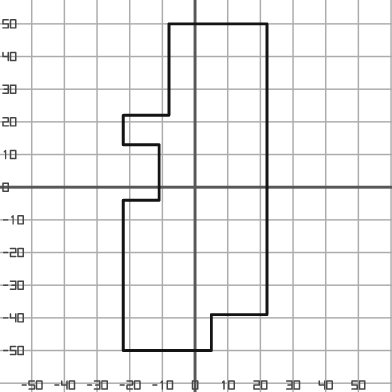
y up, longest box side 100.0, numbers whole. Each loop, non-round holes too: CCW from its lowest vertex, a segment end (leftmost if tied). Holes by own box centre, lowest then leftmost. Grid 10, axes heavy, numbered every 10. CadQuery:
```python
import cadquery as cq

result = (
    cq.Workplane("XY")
    .moveTo(-22.0, -50.0)
    .lineTo(5.0, -50.0)
    .lineTo(5.0, -39.0)
    .lineTo(22.0, -39.0)
    .lineTo(22.0, 50.0)
    .lineTo(-8.0, 50.0)
    .lineTo(-8.0, 22.0)
    .lineTo(-22.0, 22.0)
    .lineTo(-22.0, 13.0)
    .lineTo(-11.0, 13.0)
    .lineTo(-11.0, -4.0)
    .lineTo(-22.0, -4.0)
    .close()
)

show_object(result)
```